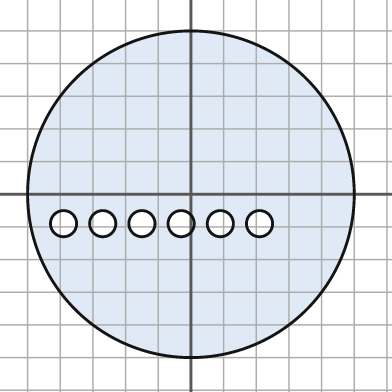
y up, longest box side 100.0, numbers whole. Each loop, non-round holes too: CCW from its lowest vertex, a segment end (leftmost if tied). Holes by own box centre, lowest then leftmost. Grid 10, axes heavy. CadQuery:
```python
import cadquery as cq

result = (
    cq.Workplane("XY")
    .moveTo(0.0, 0.0)
    .circle(50.0)
    .moveTo(-39.0, -9.0)
    .circle(4.0)
    .moveTo(-27.0, -9.0)
    .circle(4.0)
    .moveTo(-15.0, -9.0)
    .circle(4.0)
    .moveTo(-3.0, -9.0)
    .circle(4.0)
    .moveTo(9.0, -9.0)
    .circle(4.0)
    .moveTo(21.0, -9.0)
    .circle(4.0)
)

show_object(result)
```